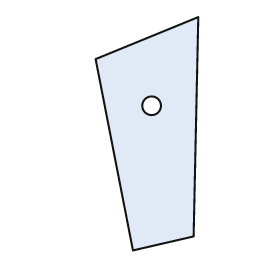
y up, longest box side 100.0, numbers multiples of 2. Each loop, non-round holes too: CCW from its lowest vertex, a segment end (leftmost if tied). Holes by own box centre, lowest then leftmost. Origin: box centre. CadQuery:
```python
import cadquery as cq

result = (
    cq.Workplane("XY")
    .moveTo(-6.0, -50.0)
    .lineTo(20.0, -44.0)
    .lineTo(22.0, 50.0)
    .lineTo(-22.0, 32.0)
    .close()
    .moveTo(2.0, 12.0)
    .circle(4.0)
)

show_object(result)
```